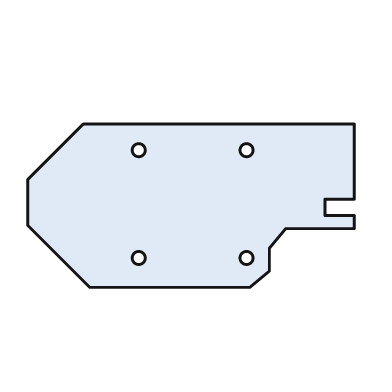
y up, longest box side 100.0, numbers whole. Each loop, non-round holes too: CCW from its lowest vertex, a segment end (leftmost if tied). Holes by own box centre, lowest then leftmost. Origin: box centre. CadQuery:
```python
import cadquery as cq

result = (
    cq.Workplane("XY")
    .moveTo(-31.0, -25.0)
    .lineTo(18.0, -25.0)
    .lineTo(24.0, -20.0)
    .lineTo(24.0, -13.0)
    .lineTo(29.0, -7.0)
    .lineTo(50.0, -7.0)
    .lineTo(50.0, -3.0)
    .lineTo(41.0, -3.0)
    .lineTo(41.0, 2.0)
    .lineTo(50.0, 2.0)
    .lineTo(50.0, 25.0)
    .lineTo(-33.0, 25.0)
    .lineTo(-50.0, 8.0)
    .lineTo(-50.0, -6.0)
    .close()
    .moveTo(-16.0, -16.0)
    .circle(2.0)
    .moveTo(17.0, -16.0)
    .circle(2.0)
    .moveTo(-16.0, 17.0)
    .circle(2.0)
    .moveTo(17.0, 17.0)
    .circle(2.0)
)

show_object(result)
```